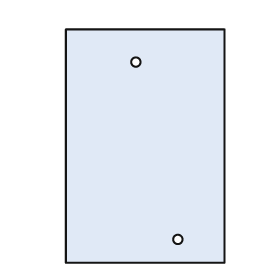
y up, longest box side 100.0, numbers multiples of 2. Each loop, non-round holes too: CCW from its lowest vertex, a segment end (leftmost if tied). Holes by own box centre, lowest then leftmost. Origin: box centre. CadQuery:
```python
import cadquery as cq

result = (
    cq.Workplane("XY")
    .moveTo(-34.0, -50.0)
    .lineTo(34.0, -50.0)
    .lineTo(34.0, 50.0)
    .lineTo(-34.0, 50.0)
    .close()
    .moveTo(14.0, -40.0)
    .circle(2.0)
    .moveTo(-4.0, 36.0)
    .circle(2.0)
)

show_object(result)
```